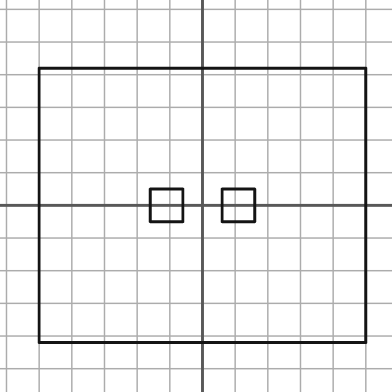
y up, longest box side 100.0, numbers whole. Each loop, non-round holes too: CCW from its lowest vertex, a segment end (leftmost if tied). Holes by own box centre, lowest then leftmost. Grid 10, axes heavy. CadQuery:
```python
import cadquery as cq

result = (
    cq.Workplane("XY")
    .moveTo(-50.0, -42.0)
    .lineTo(50.0, -42.0)
    .lineTo(50.0, 42.0)
    .lineTo(-50.0, 42.0)
    .close()
    .moveTo(-16.0, -5.0)
    .lineTo(-6.0, -5.0)
    .lineTo(-6.0, 5.0)
    .lineTo(-16.0, 5.0)
    .close()
    .moveTo(6.0, -5.0)
    .lineTo(16.0, -5.0)
    .lineTo(16.0, 5.0)
    .lineTo(6.0, 5.0)
    .close()
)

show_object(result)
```